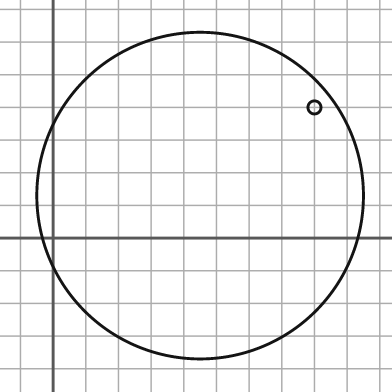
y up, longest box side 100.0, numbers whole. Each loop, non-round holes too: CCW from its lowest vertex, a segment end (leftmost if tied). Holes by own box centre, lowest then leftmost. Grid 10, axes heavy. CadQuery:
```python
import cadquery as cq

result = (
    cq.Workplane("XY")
    .moveTo(45.0, 13.0)
    .circle(50.0)
    .moveTo(80.0, 40.0)
    .circle(2.0)
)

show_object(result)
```